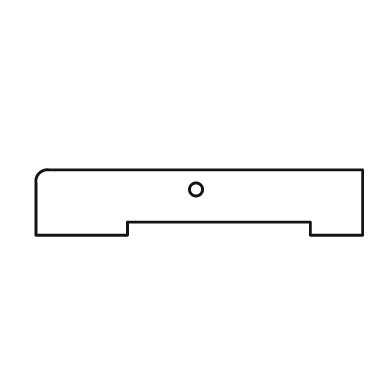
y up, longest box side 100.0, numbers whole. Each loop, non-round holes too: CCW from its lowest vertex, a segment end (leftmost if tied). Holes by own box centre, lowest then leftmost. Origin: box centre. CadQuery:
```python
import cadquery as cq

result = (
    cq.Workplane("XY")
    .moveTo(-50.0, -10.0)
    .lineTo(-22.0, -10.0)
    .lineTo(-22.0, -6.0)
    .lineTo(34.0, -6.0)
    .lineTo(34.0, -10.0)
    .lineTo(50.0, -10.0)
    .lineTo(50.0, 10.0)
    .lineTo(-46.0, 10.0)
    .threePointArc((-49.0, 9.0), (-50.0, 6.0))
    .close()
    .moveTo(-1.0, 4.0)
    .circle(2.0)
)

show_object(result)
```